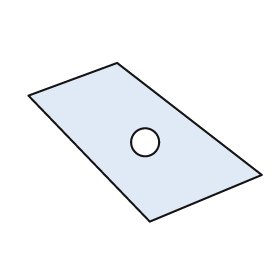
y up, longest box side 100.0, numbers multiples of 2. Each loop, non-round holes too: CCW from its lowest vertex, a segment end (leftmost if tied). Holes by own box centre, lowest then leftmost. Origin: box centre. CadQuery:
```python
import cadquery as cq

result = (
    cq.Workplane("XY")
    .moveTo(2.0, -34.0)
    .lineTo(50.0, -14.0)
    .lineTo(-12.0, 34.0)
    .lineTo(-50.0, 20.0)
    .close()
    .moveTo(0.0, 0.0)
    .circle(6.0)
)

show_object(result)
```